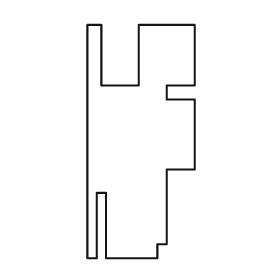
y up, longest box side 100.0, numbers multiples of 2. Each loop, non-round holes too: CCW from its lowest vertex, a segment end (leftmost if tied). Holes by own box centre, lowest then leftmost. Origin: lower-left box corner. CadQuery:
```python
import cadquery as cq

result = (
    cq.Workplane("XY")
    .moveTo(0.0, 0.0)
    .lineTo(4.0, 0.0)
    .lineTo(4.0, 28.0)
    .lineTo(8.0, 28.0)
    .lineTo(8.0, 0.0)
    .lineTo(30.0, 0.0)
    .lineTo(30.0, 6.0)
    .lineTo(34.0, 6.0)
    .lineTo(34.0, 38.0)
    .lineTo(46.0, 38.0)
    .lineTo(46.0, 68.0)
    .lineTo(34.0, 68.0)
    .lineTo(34.0, 74.0)
    .lineTo(46.0, 74.0)
    .lineTo(46.0, 100.0)
    .lineTo(22.0, 100.0)
    .lineTo(22.0, 74.0)
    .lineTo(6.0, 74.0)
    .lineTo(6.0, 100.0)
    .lineTo(0.0, 100.0)
    .close()
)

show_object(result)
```